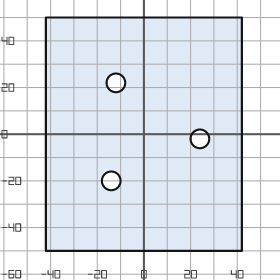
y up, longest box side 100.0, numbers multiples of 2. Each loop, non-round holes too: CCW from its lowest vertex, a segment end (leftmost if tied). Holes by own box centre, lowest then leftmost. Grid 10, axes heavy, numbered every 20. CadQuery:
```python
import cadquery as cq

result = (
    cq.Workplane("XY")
    .moveTo(-42.0, -50.0)
    .lineTo(42.0, -50.0)
    .lineTo(42.0, 50.0)
    .lineTo(-42.0, 50.0)
    .close()
    .moveTo(-14.0, -20.0)
    .circle(4.0)
    .moveTo(24.0, -2.0)
    .circle(4.0)
    .moveTo(-12.0, 22.0)
    .circle(4.0)
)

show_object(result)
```